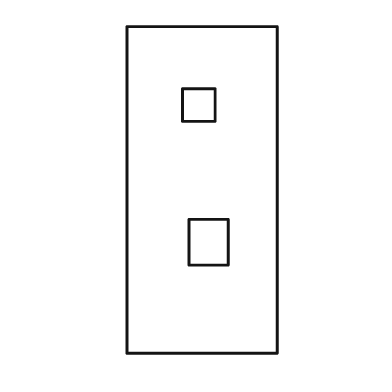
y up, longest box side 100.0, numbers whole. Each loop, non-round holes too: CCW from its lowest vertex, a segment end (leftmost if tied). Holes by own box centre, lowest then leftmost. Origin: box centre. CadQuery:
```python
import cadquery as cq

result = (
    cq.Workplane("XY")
    .moveTo(-23.0, -50.0)
    .lineTo(23.0, -50.0)
    .lineTo(23.0, 50.0)
    .lineTo(-23.0, 50.0)
    .close()
    .moveTo(-4.0, -23.0)
    .lineTo(8.0, -23.0)
    .lineTo(8.0, -9.0)
    .lineTo(-4.0, -9.0)
    .close()
    .moveTo(-6.0, 21.0)
    .lineTo(4.0, 21.0)
    .lineTo(4.0, 31.0)
    .lineTo(-6.0, 31.0)
    .close()
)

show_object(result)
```